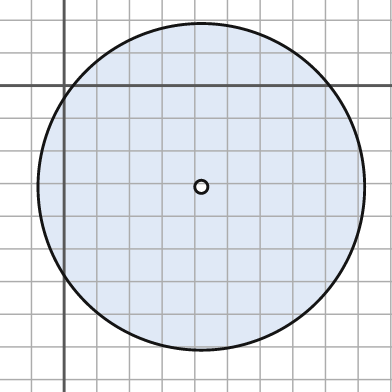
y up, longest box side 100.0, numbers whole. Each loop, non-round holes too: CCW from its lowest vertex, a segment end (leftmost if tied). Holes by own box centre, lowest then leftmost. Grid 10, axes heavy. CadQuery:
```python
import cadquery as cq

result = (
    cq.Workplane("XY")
    .moveTo(42.0, -31.0)
    .circle(50.0)
    .moveTo(42.0, -31.0)
    .circle(2.0)
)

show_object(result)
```